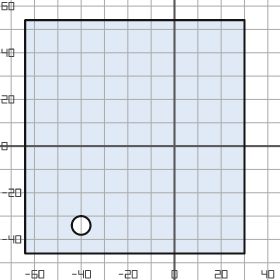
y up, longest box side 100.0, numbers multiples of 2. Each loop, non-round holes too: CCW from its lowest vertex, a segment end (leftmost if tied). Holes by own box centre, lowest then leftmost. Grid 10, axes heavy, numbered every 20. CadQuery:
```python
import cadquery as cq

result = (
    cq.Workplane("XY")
    .moveTo(-64.0, -46.0)
    .lineTo(30.0, -46.0)
    .lineTo(30.0, 54.0)
    .lineTo(-64.0, 54.0)
    .close()
    .moveTo(-40.0, -34.0)
    .circle(4.0)
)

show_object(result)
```